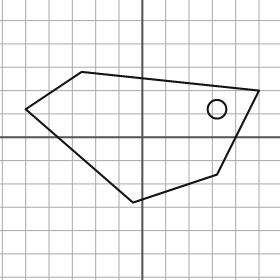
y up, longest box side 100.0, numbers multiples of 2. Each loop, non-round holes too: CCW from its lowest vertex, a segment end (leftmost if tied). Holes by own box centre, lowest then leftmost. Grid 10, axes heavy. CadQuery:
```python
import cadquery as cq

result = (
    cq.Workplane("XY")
    .moveTo(-4.0, -28.0)
    .lineTo(32.0, -16.0)
    .lineTo(50.0, 20.0)
    .lineTo(-26.0, 28.0)
    .lineTo(-50.0, 12.0)
    .close()
    .moveTo(32.0, 12.0)
    .circle(4.0)
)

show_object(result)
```